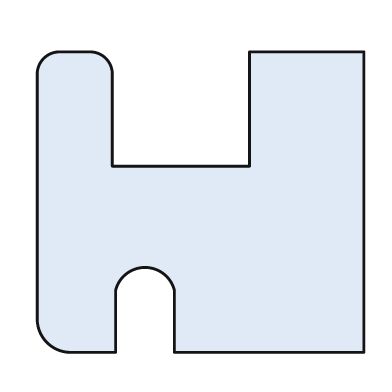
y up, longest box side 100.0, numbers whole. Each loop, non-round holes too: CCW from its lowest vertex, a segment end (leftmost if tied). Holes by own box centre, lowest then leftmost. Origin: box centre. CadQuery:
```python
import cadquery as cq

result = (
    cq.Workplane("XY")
    .moveTo(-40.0, -46.0)
    .lineTo(-26.0, -46.0)
    .lineTo(-26.0, -27.0)
    .threePointArc((-17.0, -20.0), (-8.0, -27.0))
    .lineTo(-8.0, -46.0)
    .lineTo(50.0, -46.0)
    .lineTo(50.0, 46.0)
    .lineTo(15.0, 46.0)
    .lineTo(15.0, 11.0)
    .lineTo(-27.0, 11.0)
    .lineTo(-27.0, 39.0)
    .threePointArc((-29.0, 44.0), (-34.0, 46.0))
    .lineTo(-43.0, 46.0)
    .threePointArc((-48.0, 44.0), (-50.0, 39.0))
    .lineTo(-50.0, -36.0)
    .threePointArc((-47.0, -43.0), (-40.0, -46.0))
    .close()
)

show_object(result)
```